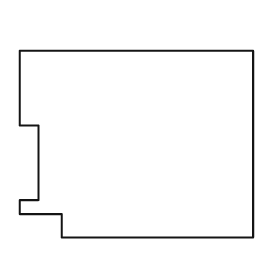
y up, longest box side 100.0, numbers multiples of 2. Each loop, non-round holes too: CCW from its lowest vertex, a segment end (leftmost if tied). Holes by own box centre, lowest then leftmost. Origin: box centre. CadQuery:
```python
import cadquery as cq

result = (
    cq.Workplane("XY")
    .moveTo(-32.0, -40.0)
    .lineTo(50.0, -40.0)
    .lineTo(50.0, 40.0)
    .lineTo(-50.0, 40.0)
    .lineTo(-50.0, 8.0)
    .lineTo(-42.0, 8.0)
    .lineTo(-42.0, -24.0)
    .lineTo(-50.0, -24.0)
    .lineTo(-50.0, -30.0)
    .lineTo(-32.0, -30.0)
    .close()
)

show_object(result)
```